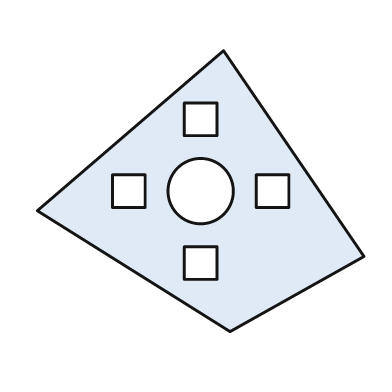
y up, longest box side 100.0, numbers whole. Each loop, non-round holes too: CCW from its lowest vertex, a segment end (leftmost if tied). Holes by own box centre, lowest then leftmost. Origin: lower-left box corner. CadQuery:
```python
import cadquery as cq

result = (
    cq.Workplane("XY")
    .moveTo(59.0, 0.0)
    .lineTo(100.0, 23.0)
    .lineTo(57.0, 86.0)
    .lineTo(0.0, 37.0)
    .close()
    .moveTo(45.0, 16.0)
    .lineTo(55.0, 16.0)
    .lineTo(55.0, 26.0)
    .lineTo(45.0, 26.0)
    .close()
    .moveTo(23.0, 38.0)
    .lineTo(33.0, 38.0)
    .lineTo(33.0, 48.0)
    .lineTo(23.0, 48.0)
    .close()
    .moveTo(50.0, 43.0)
    .circle(10.0)
    .moveTo(67.0, 38.0)
    .lineTo(77.0, 38.0)
    .lineTo(77.0, 48.0)
    .lineTo(67.0, 48.0)
    .close()
    .moveTo(45.0, 60.0)
    .lineTo(55.0, 60.0)
    .lineTo(55.0, 70.0)
    .lineTo(45.0, 70.0)
    .close()
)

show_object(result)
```